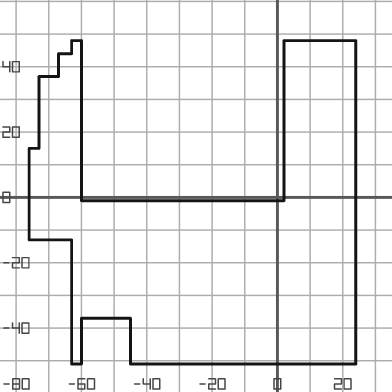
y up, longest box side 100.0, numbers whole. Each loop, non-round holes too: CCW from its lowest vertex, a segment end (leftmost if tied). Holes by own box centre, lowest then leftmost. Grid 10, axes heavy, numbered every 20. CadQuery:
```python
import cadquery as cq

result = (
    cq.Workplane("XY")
    .moveTo(-63.0, -51.0)
    .lineTo(-60.0, -51.0)
    .lineTo(-60.0, -37.0)
    .lineTo(-45.0, -37.0)
    .lineTo(-45.0, -51.0)
    .lineTo(24.0, -51.0)
    .lineTo(24.0, 48.0)
    .lineTo(2.0, 48.0)
    .lineTo(2.0, -1.0)
    .lineTo(-60.0, -1.0)
    .lineTo(-60.0, 48.0)
    .lineTo(-63.0, 48.0)
    .lineTo(-63.0, 44.0)
    .lineTo(-67.0, 44.0)
    .lineTo(-67.0, 37.0)
    .lineTo(-73.0, 37.0)
    .lineTo(-73.0, 15.0)
    .lineTo(-76.0, 15.0)
    .lineTo(-76.0, -13.0)
    .lineTo(-63.0, -13.0)
    .close()
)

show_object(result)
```